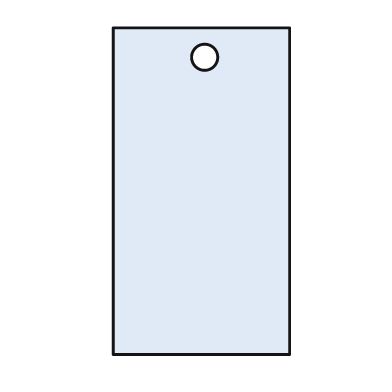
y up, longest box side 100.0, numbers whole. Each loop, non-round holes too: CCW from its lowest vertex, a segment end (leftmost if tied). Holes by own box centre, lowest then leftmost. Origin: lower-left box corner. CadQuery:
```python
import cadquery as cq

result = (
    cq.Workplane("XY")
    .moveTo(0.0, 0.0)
    .lineTo(54.0, 0.0)
    .lineTo(54.0, 100.0)
    .lineTo(0.0, 100.0)
    .close()
    .moveTo(28.0, 91.0)
    .circle(4.0)
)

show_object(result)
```